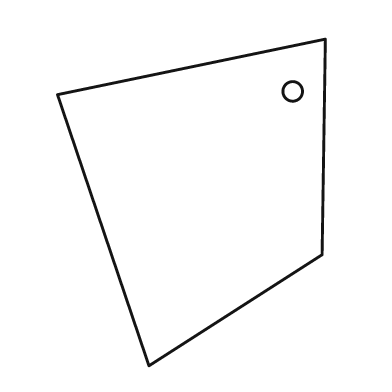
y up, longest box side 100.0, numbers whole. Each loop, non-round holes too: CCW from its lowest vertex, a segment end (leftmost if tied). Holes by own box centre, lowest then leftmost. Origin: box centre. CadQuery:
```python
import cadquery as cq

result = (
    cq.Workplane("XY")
    .moveTo(-13.0, -50.0)
    .lineTo(40.0, -16.0)
    .lineTo(41.0, 50.0)
    .lineTo(-41.0, 33.0)
    .close()
    .moveTo(31.0, 34.0)
    .circle(3.0)
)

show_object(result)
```